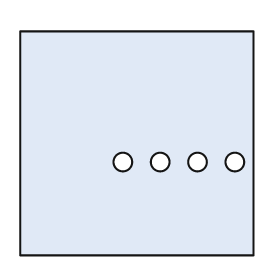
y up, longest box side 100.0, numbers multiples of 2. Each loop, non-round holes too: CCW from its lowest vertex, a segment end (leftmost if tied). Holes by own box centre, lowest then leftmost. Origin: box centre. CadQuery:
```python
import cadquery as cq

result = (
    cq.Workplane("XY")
    .moveTo(-50.0, -48.0)
    .lineTo(50.0, -48.0)
    .lineTo(50.0, 48.0)
    .lineTo(-50.0, 48.0)
    .close()
    .moveTo(-6.0, -8.0)
    .circle(4.0)
    .moveTo(10.0, -8.0)
    .circle(4.0)
    .moveTo(26.0, -8.0)
    .circle(4.0)
    .moveTo(42.0, -8.0)
    .circle(4.0)
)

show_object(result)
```